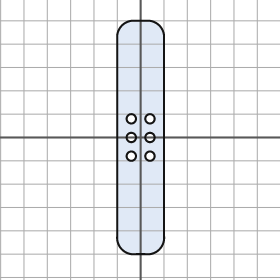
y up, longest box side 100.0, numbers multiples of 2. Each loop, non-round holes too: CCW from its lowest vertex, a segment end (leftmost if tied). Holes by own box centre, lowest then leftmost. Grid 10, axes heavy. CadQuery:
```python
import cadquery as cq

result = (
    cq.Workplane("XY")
    .moveTo(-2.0, -50.0)
    .lineTo(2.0, -50.0)
    .threePointArc((8.0, -48.0), (10.0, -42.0))
    .lineTo(10.0, 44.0)
    .threePointArc((8.0, 48.0), (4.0, 50.0))
    .lineTo(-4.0, 50.0)
    .threePointArc((-8.0, 48.0), (-10.0, 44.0))
    .lineTo(-10.0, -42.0)
    .threePointArc((-8.0, -48.0), (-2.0, -50.0))
    .close()
    .moveTo(-4.0, -8.0)
    .circle(2.0)
    .moveTo(4.0, -8.0)
    .circle(2.0)
    .moveTo(-4.0, 0.0)
    .circle(2.0)
    .moveTo(4.0, 0.0)
    .circle(2.0)
    .moveTo(-4.0, 8.0)
    .circle(2.0)
    .moveTo(4.0, 8.0)
    .circle(2.0)
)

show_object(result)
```